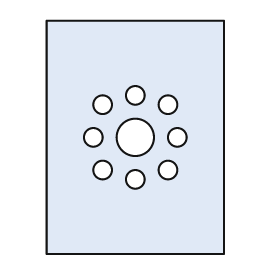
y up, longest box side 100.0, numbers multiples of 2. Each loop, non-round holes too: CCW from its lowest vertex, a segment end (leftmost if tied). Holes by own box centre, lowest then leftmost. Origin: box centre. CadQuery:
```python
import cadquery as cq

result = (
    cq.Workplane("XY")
    .moveTo(-38.0, -50.0)
    .lineTo(38.0, -50.0)
    .lineTo(38.0, 50.0)
    .lineTo(-38.0, 50.0)
    .close()
    .moveTo(0.0, -18.0)
    .circle(4.0)
    .moveTo(-14.0, -14.0)
    .circle(4.0)
    .moveTo(14.0, -14.0)
    .circle(4.0)
    .moveTo(-18.0, 0.0)
    .circle(4.0)
    .moveTo(0.0, 0.0)
    .circle(8.0)
    .moveTo(18.0, 0.0)
    .circle(4.0)
    .moveTo(-14.0, 14.0)
    .circle(4.0)
    .moveTo(14.0, 14.0)
    .circle(4.0)
    .moveTo(0.0, 18.0)
    .circle(4.0)
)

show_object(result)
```